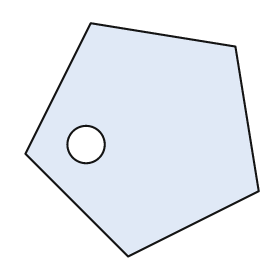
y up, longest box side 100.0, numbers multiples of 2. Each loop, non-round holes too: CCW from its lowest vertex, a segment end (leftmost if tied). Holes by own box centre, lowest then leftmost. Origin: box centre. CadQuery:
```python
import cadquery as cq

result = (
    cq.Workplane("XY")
    .moveTo(-6.0, -50.0)
    .lineTo(50.0, -22.0)
    .lineTo(40.0, 40.0)
    .lineTo(-22.0, 50.0)
    .lineTo(-50.0, -6.0)
    .close()
    .moveTo(-24.0, -2.0)
    .circle(8.0)
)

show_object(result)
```